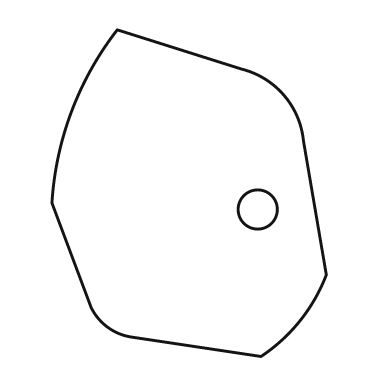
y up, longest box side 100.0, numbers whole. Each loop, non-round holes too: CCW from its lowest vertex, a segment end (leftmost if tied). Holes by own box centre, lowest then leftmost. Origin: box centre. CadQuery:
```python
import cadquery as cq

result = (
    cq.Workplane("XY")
    .moveTo(22.0, -50.0)
    .threePointArc((34.0, -39.0), (42.0, -25.0))
    .lineTo(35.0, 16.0)
    .threePointArc((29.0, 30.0), (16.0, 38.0))
    .lineTo(-22.0, 50.0)
    .threePointArc((-36.0, 25.0), (-42.0, -3.0))
    .lineTo(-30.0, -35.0)
    .threePointArc((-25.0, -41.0), (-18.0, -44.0))
    .close()
    .moveTo(21.0, -5.0)
    .circle(6.0)
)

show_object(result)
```